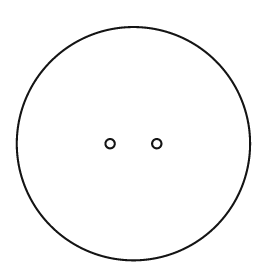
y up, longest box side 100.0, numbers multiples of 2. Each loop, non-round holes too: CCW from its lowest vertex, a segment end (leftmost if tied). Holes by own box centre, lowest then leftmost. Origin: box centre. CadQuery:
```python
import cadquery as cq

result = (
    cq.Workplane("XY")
    .moveTo(0.0, 0.0)
    .circle(50.0)
    .moveTo(-10.0, 0.0)
    .circle(2.0)
    .moveTo(10.0, 0.0)
    .circle(2.0)
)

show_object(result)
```